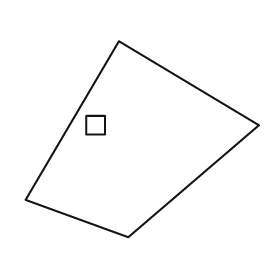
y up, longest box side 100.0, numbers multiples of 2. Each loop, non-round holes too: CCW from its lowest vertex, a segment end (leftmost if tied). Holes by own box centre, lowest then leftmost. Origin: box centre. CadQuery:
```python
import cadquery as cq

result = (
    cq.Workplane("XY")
    .moveTo(-6.0, -42.0)
    .lineTo(50.0, 6.0)
    .lineTo(-10.0, 42.0)
    .lineTo(-50.0, -26.0)
    .close()
    .moveTo(-24.0, 2.0)
    .lineTo(-16.0, 2.0)
    .lineTo(-16.0, 10.0)
    .lineTo(-24.0, 10.0)
    .close()
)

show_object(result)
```